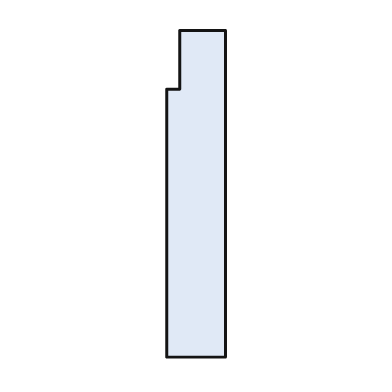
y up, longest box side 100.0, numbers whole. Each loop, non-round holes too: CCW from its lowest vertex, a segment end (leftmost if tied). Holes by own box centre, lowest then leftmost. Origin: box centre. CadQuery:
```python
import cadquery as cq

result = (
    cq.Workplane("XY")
    .moveTo(-9.0, -50.0)
    .lineTo(9.0, -50.0)
    .lineTo(9.0, 50.0)
    .lineTo(-5.0, 50.0)
    .lineTo(-5.0, 32.0)
    .lineTo(-9.0, 32.0)
    .close()
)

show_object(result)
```